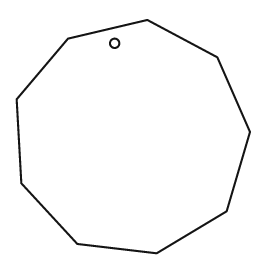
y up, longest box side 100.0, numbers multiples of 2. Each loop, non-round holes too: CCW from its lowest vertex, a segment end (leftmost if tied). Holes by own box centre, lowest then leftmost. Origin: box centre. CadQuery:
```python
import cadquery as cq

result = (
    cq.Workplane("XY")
    .moveTo(10.0, -50.0)
    .lineTo(40.0, -32.0)
    .lineTo(50.0, 2.0)
    .lineTo(36.0, 34.0)
    .lineTo(6.0, 50.0)
    .lineTo(-28.0, 42.0)
    .lineTo(-50.0, 16.0)
    .lineTo(-48.0, -20.0)
    .lineTo(-24.0, -46.0)
    .close()
    .moveTo(-8.0, 40.0)
    .circle(2.0)
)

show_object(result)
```